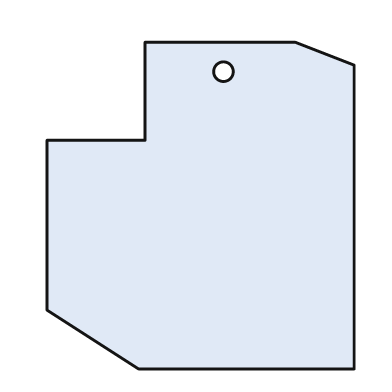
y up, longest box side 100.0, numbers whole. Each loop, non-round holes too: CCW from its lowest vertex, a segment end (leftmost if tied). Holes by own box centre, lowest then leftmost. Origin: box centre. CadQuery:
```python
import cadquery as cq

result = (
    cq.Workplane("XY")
    .moveTo(-19.0, -50.0)
    .lineTo(47.0, -50.0)
    .lineTo(47.0, 43.0)
    .lineTo(29.0, 50.0)
    .lineTo(-17.0, 50.0)
    .lineTo(-17.0, 20.0)
    .lineTo(-47.0, 20.0)
    .lineTo(-47.0, -32.0)
    .close()
    .moveTo(7.0, 41.0)
    .circle(3.0)
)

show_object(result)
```